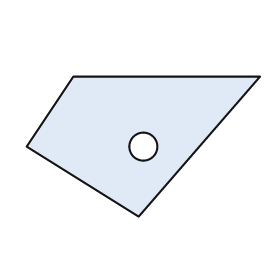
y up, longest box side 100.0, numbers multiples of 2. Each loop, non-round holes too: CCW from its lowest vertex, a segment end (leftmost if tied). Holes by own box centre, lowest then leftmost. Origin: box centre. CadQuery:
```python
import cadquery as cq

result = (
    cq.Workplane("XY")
    .moveTo(-2.0, -30.0)
    .lineTo(50.0, 30.0)
    .lineTo(-30.0, 30.0)
    .lineTo(-50.0, 0.0)
    .close()
    .moveTo(0.0, 0.0)
    .circle(6.0)
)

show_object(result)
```